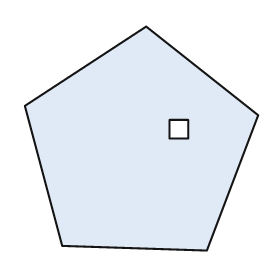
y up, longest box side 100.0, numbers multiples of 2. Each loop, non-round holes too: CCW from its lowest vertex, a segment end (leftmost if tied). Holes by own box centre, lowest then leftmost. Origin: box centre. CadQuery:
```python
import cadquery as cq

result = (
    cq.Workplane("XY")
    .moveTo(28.0, -48.0)
    .lineTo(50.0, 10.0)
    .lineTo(2.0, 48.0)
    .lineTo(-50.0, 14.0)
    .lineTo(-34.0, -46.0)
    .close()
    .moveTo(12.0, 0.0)
    .lineTo(20.0, 0.0)
    .lineTo(20.0, 8.0)
    .lineTo(12.0, 8.0)
    .close()
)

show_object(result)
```